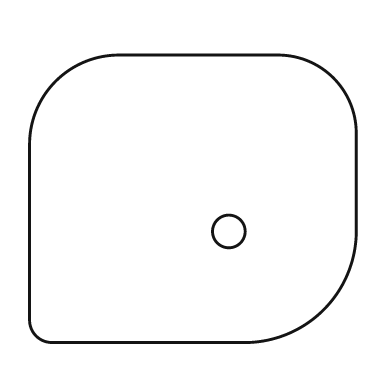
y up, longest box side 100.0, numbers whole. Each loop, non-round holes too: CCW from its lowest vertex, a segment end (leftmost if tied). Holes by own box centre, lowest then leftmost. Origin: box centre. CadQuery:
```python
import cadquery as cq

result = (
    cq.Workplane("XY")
    .moveTo(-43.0, -44.0)
    .lineTo(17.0, -44.0)
    .threePointArc((40.0, -34.0), (50.0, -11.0))
    .lineTo(50.0, 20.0)
    .threePointArc((43.0, 37.0), (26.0, 44.0))
    .lineTo(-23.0, 44.0)
    .threePointArc((-42.0, 36.0), (-50.0, 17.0))
    .lineTo(-50.0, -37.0)
    .threePointArc((-48.0, -42.0), (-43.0, -44.0))
    .close()
    .moveTo(11.0, -10.0)
    .circle(5.0)
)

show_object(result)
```